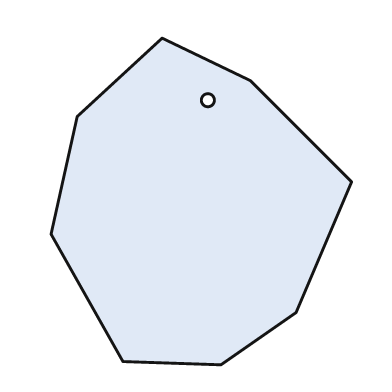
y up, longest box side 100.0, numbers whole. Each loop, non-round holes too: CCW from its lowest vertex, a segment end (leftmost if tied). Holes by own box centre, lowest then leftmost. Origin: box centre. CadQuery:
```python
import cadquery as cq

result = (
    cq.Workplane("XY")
    .moveTo(6.0, -50.0)
    .lineTo(29.0, -34.0)
    .lineTo(46.0, 6.0)
    .lineTo(15.0, 37.0)
    .lineTo(-12.0, 50.0)
    .lineTo(-38.0, 26.0)
    .lineTo(-46.0, -10.0)
    .lineTo(-24.0, -49.0)
    .close()
    .moveTo(2.0, 31.0)
    .circle(2.0)
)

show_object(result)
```